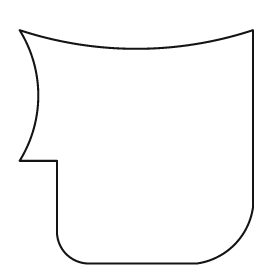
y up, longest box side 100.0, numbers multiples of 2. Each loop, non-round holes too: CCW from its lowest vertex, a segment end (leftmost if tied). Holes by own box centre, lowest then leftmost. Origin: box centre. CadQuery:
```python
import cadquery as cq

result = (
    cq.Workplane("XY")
    .moveTo(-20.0, -50.0)
    .lineTo(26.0, -50.0)
    .threePointArc((42.0, -42.0), (50.0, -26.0))
    .lineTo(50.0, 50.0)
    .threePointArc((0.0, 42.0), (-50.0, 50.0))
    .threePointArc((-42.0, 22.0), (-50.0, -6.0))
    .lineTo(-34.0, -6.0)
    .lineTo(-34.0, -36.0)
    .threePointArc((-30.0, -46.0), (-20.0, -50.0))
    .close()
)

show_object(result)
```